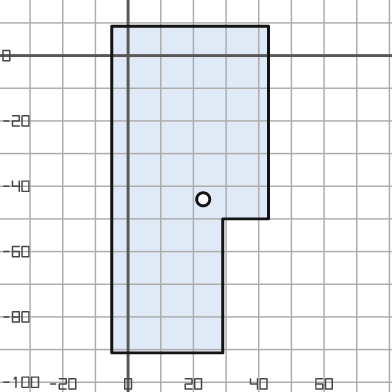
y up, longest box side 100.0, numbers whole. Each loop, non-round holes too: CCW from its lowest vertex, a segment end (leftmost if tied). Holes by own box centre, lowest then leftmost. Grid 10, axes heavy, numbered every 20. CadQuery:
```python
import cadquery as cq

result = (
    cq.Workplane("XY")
    .moveTo(-5.0, -91.0)
    .lineTo(29.0, -91.0)
    .lineTo(29.0, -50.0)
    .lineTo(43.0, -50.0)
    .lineTo(43.0, 9.0)
    .lineTo(-5.0, 9.0)
    .close()
    .moveTo(23.0, -44.0)
    .circle(2.0)
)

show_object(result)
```